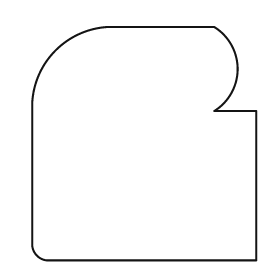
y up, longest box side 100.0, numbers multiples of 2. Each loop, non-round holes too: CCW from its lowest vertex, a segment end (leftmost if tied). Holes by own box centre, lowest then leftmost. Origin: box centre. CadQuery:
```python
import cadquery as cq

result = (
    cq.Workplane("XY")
    .moveTo(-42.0, -50.0)
    .lineTo(48.0, -50.0)
    .lineTo(48.0, 14.0)
    .lineTo(30.0, 14.0)
    .threePointArc((40.0, 32.0), (30.0, 50.0))
    .lineTo(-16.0, 50.0)
    .threePointArc((-38.0, 40.0), (-48.0, 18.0))
    .lineTo(-48.0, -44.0)
    .threePointArc((-46.0, -48.0), (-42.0, -50.0))
    .close()
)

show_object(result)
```